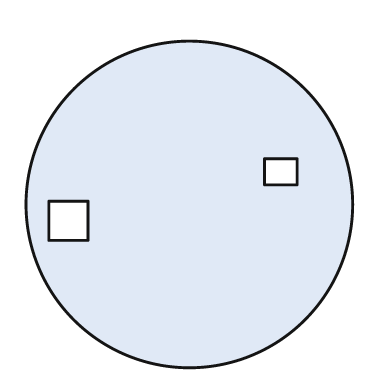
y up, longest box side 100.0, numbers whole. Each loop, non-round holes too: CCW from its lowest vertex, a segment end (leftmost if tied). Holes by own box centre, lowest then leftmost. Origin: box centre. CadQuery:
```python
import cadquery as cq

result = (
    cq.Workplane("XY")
    .moveTo(0.0, 0.0)
    .circle(50.0)
    .moveTo(-43.0, -11.0)
    .lineTo(-31.0, -11.0)
    .lineTo(-31.0, 1.0)
    .lineTo(-43.0, 1.0)
    .close()
    .moveTo(23.0, 6.0)
    .lineTo(33.0, 6.0)
    .lineTo(33.0, 14.0)
    .lineTo(23.0, 14.0)
    .close()
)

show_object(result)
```